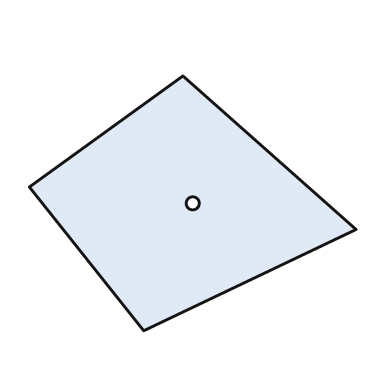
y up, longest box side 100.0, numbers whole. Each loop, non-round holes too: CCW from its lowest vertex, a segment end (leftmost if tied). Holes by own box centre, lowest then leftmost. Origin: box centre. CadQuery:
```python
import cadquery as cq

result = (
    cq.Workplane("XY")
    .moveTo(-15.0, -39.0)
    .lineTo(50.0, -8.0)
    .lineTo(-3.0, 39.0)
    .lineTo(-50.0, 5.0)
    .close()
    .moveTo(0.0, 0.0)
    .circle(2.0)
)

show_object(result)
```